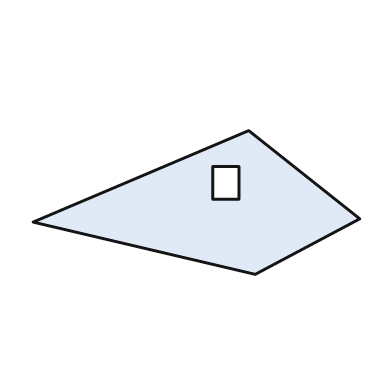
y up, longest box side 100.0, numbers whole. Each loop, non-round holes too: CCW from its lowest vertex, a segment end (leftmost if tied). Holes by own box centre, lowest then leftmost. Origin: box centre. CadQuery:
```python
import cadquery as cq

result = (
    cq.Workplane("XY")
    .moveTo(18.0, -22.0)
    .lineTo(50.0, -5.0)
    .lineTo(16.0, 22.0)
    .lineTo(-50.0, -6.0)
    .close()
    .moveTo(5.0, 1.0)
    .lineTo(13.0, 1.0)
    .lineTo(13.0, 11.0)
    .lineTo(5.0, 11.0)
    .close()
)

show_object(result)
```